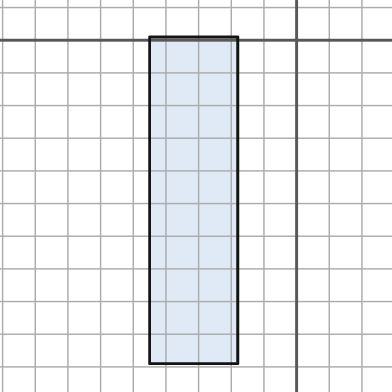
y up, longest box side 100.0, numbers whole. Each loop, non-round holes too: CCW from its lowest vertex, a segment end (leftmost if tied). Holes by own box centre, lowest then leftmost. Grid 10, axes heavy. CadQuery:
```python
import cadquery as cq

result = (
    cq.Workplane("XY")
    .moveTo(-45.0, -99.0)
    .lineTo(-18.0, -99.0)
    .lineTo(-18.0, 1.0)
    .lineTo(-45.0, 1.0)
    .close()
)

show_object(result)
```